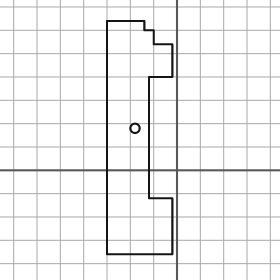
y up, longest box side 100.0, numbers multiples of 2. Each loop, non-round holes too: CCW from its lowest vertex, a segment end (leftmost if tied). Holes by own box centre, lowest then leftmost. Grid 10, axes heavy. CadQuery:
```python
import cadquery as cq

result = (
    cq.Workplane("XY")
    .moveTo(-30.0, -36.0)
    .lineTo(-2.0, -36.0)
    .lineTo(-2.0, -12.0)
    .lineTo(-12.0, -12.0)
    .lineTo(-12.0, 40.0)
    .lineTo(-2.0, 40.0)
    .lineTo(-2.0, 54.0)
    .lineTo(-10.0, 54.0)
    .lineTo(-10.0, 60.0)
    .lineTo(-14.0, 60.0)
    .lineTo(-14.0, 64.0)
    .lineTo(-30.0, 64.0)
    .close()
    .moveTo(-18.0, 18.0)
    .circle(2.0)
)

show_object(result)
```